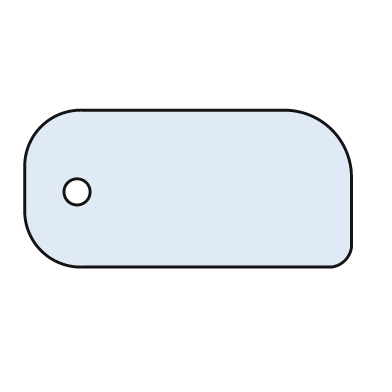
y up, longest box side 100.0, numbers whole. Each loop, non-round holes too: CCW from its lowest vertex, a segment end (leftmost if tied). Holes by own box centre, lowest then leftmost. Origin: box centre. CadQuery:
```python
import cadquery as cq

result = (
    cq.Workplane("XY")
    .moveTo(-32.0, -24.0)
    .lineTo(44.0, -24.0)
    .threePointArc((48.0, -22.0), (50.0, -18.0))
    .lineTo(50.0, 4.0)
    .threePointArc((44.0, 18.0), (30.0, 24.0))
    .lineTo(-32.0, 24.0)
    .threePointArc((-45.0, 19.0), (-50.0, 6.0))
    .lineTo(-50.0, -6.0)
    .threePointArc((-45.0, -19.0), (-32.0, -24.0))
    .close()
    .moveTo(-34.0, -1.0)
    .circle(4.0)
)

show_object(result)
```